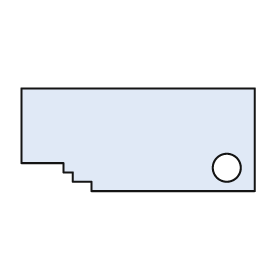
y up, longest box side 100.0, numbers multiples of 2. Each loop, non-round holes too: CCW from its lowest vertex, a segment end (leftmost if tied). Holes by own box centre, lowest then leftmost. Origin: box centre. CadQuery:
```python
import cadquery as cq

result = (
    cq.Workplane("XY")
    .moveTo(-20.0, -22.0)
    .lineTo(50.0, -22.0)
    .lineTo(50.0, 22.0)
    .lineTo(-50.0, 22.0)
    .lineTo(-50.0, -10.0)
    .lineTo(-32.0, -10.0)
    .lineTo(-32.0, -14.0)
    .lineTo(-28.0, -14.0)
    .lineTo(-28.0, -18.0)
    .lineTo(-20.0, -18.0)
    .close()
    .moveTo(38.0, -12.0)
    .circle(6.0)
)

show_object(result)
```